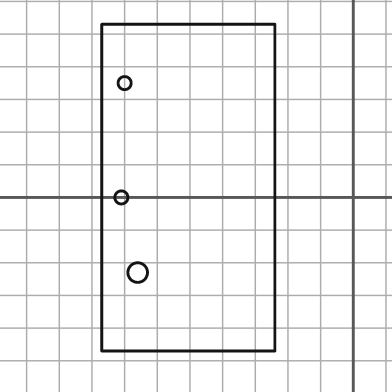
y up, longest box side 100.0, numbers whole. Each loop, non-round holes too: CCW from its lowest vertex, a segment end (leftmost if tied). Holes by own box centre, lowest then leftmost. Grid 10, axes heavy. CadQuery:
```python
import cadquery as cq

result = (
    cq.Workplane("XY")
    .moveTo(-77.0, -47.0)
    .lineTo(-24.0, -47.0)
    .lineTo(-24.0, 53.0)
    .lineTo(-77.0, 53.0)
    .close()
    .moveTo(-66.0, -23.0)
    .circle(3.0)
    .moveTo(-71.0, 0.0)
    .circle(2.0)
    .moveTo(-70.0, 35.0)
    .circle(2.0)
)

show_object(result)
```